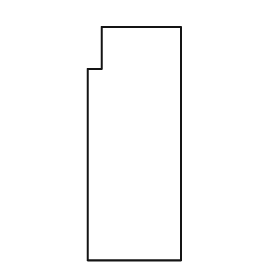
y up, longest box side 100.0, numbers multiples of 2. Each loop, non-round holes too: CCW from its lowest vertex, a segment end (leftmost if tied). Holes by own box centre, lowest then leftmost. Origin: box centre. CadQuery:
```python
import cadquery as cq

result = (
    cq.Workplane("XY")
    .moveTo(-20.0, -50.0)
    .lineTo(20.0, -50.0)
    .lineTo(20.0, 50.0)
    .lineTo(-14.0, 50.0)
    .lineTo(-14.0, 32.0)
    .lineTo(-20.0, 32.0)
    .close()
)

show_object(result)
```